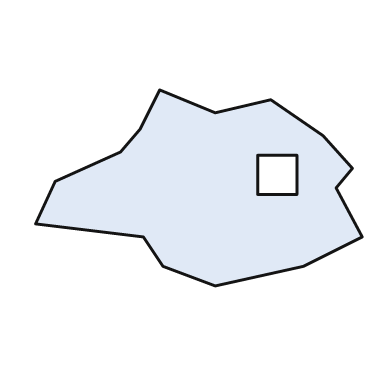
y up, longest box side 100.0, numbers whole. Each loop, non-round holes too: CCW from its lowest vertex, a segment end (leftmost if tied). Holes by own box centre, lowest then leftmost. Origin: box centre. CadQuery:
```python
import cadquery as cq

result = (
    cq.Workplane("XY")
    .moveTo(5.0, -30.0)
    .lineTo(32.0, -24.0)
    .lineTo(50.0, -15.0)
    .lineTo(42.0, 0.0)
    .lineTo(47.0, 6.0)
    .lineTo(38.0, 16.0)
    .lineTo(22.0, 27.0)
    .lineTo(5.0, 23.0)
    .lineTo(-12.0, 30.0)
    .lineTo(-18.0, 18.0)
    .lineTo(-24.0, 11.0)
    .lineTo(-44.0, 2.0)
    .lineTo(-50.0, -11.0)
    .lineTo(-17.0, -15.0)
    .lineTo(-11.0, -24.0)
    .close()
    .moveTo(18.0, -2.0)
    .lineTo(30.0, -2.0)
    .lineTo(30.0, 10.0)
    .lineTo(18.0, 10.0)
    .close()
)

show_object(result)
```